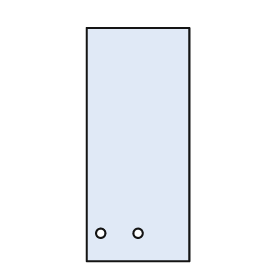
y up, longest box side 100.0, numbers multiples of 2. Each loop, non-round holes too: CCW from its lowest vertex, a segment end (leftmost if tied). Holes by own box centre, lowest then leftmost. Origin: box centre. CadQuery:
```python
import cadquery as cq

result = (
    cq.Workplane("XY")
    .moveTo(-22.0, -50.0)
    .lineTo(22.0, -50.0)
    .lineTo(22.0, 50.0)
    .lineTo(-22.0, 50.0)
    .close()
    .moveTo(-16.0, -38.0)
    .circle(2.0)
    .moveTo(0.0, -38.0)
    .circle(2.0)
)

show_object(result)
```